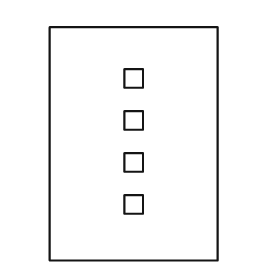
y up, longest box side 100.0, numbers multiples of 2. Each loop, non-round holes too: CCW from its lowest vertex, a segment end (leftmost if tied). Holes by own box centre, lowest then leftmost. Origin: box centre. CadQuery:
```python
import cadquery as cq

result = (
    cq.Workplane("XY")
    .moveTo(-36.0, -50.0)
    .lineTo(36.0, -50.0)
    .lineTo(36.0, 50.0)
    .lineTo(-36.0, 50.0)
    .close()
    .moveTo(-4.0, -30.0)
    .lineTo(4.0, -30.0)
    .lineTo(4.0, -22.0)
    .lineTo(-4.0, -22.0)
    .close()
    .moveTo(-4.0, -12.0)
    .lineTo(4.0, -12.0)
    .lineTo(4.0, -4.0)
    .lineTo(-4.0, -4.0)
    .close()
    .moveTo(-4.0, 6.0)
    .lineTo(4.0, 6.0)
    .lineTo(4.0, 14.0)
    .lineTo(-4.0, 14.0)
    .close()
    .moveTo(-4.0, 24.0)
    .lineTo(4.0, 24.0)
    .lineTo(4.0, 32.0)
    .lineTo(-4.0, 32.0)
    .close()
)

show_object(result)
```